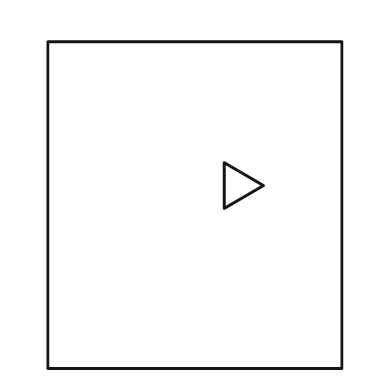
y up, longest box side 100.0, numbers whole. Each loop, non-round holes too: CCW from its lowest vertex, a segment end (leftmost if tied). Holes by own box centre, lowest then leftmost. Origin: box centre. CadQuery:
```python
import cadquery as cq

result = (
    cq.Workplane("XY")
    .moveTo(-45.0, -50.0)
    .lineTo(45.0, -50.0)
    .lineTo(45.0, 50.0)
    .lineTo(-45.0, 50.0)
    .close()
    .moveTo(9.0, -1.0)
    .lineTo(21.0, 6.0)
    .lineTo(9.0, 13.0)
    .close()
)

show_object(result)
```